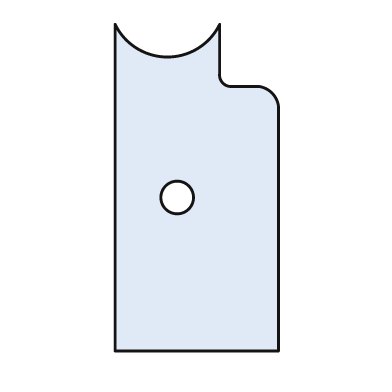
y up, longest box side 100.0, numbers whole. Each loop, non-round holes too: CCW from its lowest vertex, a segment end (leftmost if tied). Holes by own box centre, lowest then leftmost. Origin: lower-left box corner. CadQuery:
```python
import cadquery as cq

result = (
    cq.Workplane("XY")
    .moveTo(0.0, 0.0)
    .lineTo(50.0, 0.0)
    .lineTo(50.0, 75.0)
    .threePointArc((48.0, 79.0), (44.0, 81.0))
    .lineTo(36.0, 81.0)
    .threePointArc((33.0, 82.0), (32.0, 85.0))
    .lineTo(32.0, 100.0)
    .threePointArc((16.0, 90.0), (0.0, 100.0))
    .close()
    .moveTo(19.0, 47.0)
    .circle(5.0)
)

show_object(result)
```